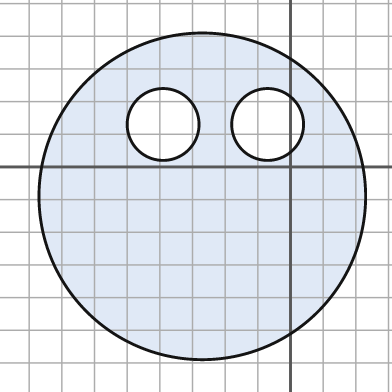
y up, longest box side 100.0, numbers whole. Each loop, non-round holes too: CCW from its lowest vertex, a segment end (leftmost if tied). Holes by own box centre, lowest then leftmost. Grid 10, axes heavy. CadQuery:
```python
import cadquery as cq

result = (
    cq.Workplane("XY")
    .moveTo(-27.0, -9.0)
    .circle(50.0)
    .moveTo(-39.0, 13.0)
    .circle(11.0)
    .moveTo(-7.0, 13.0)
    .circle(11.0)
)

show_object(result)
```